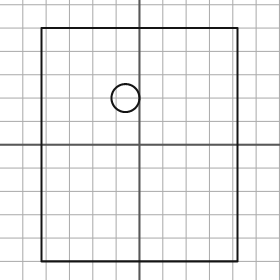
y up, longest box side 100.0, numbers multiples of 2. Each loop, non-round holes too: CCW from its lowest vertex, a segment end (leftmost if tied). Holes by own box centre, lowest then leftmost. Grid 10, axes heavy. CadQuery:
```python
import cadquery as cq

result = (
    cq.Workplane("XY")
    .moveTo(-42.0, -50.0)
    .lineTo(42.0, -50.0)
    .lineTo(42.0, 50.0)
    .lineTo(-42.0, 50.0)
    .close()
    .moveTo(-6.0, 20.0)
    .circle(6.0)
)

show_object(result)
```